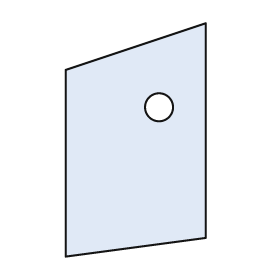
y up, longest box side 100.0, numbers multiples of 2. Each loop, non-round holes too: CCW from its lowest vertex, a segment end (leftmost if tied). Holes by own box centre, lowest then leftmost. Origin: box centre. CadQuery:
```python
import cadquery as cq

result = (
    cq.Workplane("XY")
    .moveTo(-30.0, -50.0)
    .lineTo(30.0, -42.0)
    .lineTo(30.0, 50.0)
    .lineTo(-30.0, 30.0)
    .close()
    .moveTo(10.0, 14.0)
    .circle(6.0)
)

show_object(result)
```